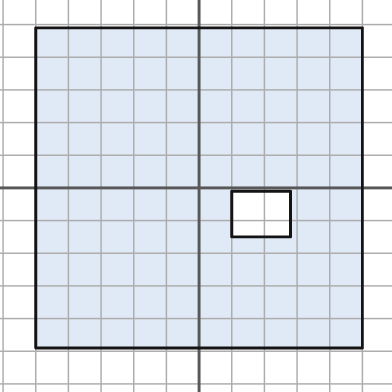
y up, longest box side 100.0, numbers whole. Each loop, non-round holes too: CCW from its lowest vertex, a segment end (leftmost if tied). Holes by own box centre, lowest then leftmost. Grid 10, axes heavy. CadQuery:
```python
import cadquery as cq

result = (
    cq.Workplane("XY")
    .moveTo(-50.0, -49.0)
    .lineTo(50.0, -49.0)
    .lineTo(50.0, 49.0)
    .lineTo(-50.0, 49.0)
    .close()
    .moveTo(10.0, -15.0)
    .lineTo(28.0, -15.0)
    .lineTo(28.0, -1.0)
    .lineTo(10.0, -1.0)
    .close()
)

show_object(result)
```